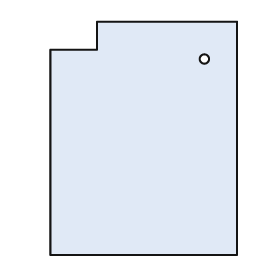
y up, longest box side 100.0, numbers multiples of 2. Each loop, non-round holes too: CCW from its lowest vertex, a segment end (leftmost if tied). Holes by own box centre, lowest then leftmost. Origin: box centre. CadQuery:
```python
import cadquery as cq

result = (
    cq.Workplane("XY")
    .moveTo(-40.0, -50.0)
    .lineTo(40.0, -50.0)
    .lineTo(40.0, 50.0)
    .lineTo(-20.0, 50.0)
    .lineTo(-20.0, 38.0)
    .lineTo(-40.0, 38.0)
    .close()
    .moveTo(26.0, 34.0)
    .circle(2.0)
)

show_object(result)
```